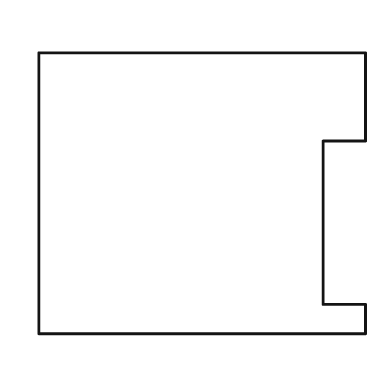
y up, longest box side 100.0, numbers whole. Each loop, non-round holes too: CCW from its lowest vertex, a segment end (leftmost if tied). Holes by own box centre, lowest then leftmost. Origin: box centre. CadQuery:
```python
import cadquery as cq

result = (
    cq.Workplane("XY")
    .moveTo(-50.0, -43.0)
    .lineTo(50.0, -43.0)
    .lineTo(50.0, -34.0)
    .lineTo(37.0, -34.0)
    .lineTo(37.0, 16.0)
    .lineTo(50.0, 16.0)
    .lineTo(50.0, 43.0)
    .lineTo(-50.0, 43.0)
    .close()
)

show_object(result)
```